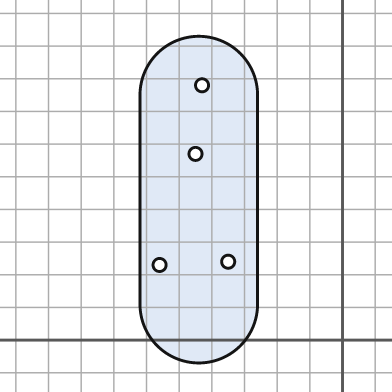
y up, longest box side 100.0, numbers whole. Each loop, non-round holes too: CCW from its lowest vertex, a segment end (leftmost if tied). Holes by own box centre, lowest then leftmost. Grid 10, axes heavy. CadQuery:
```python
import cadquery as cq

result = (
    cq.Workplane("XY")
    .moveTo(-62.0, 11.0)
    .threePointArc((-44.0, -7.0), (-26.0, 11.0))
    .lineTo(-26.0, 75.0)
    .threePointArc((-44.0, 93.0), (-62.0, 75.0))
    .close()
    .moveTo(-56.0, 23.0)
    .circle(2.0)
    .moveTo(-35.0, 24.0)
    .circle(2.0)
    .moveTo(-45.0, 57.0)
    .circle(2.0)
    .moveTo(-43.0, 78.0)
    .circle(2.0)
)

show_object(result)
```